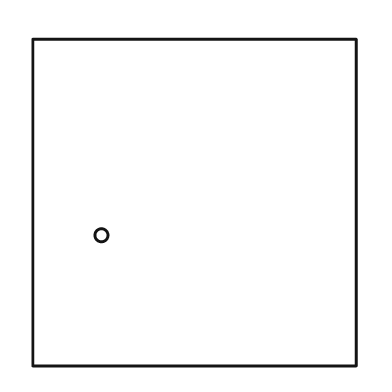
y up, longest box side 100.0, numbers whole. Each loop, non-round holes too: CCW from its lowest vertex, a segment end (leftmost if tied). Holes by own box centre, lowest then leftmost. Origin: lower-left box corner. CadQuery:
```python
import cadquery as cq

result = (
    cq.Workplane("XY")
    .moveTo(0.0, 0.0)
    .lineTo(99.0, 0.0)
    .lineTo(99.0, 100.0)
    .lineTo(0.0, 100.0)
    .close()
    .moveTo(21.0, 40.0)
    .circle(2.0)
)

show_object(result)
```